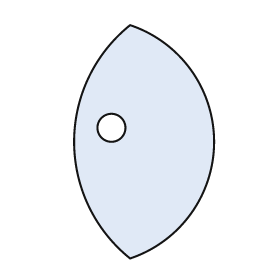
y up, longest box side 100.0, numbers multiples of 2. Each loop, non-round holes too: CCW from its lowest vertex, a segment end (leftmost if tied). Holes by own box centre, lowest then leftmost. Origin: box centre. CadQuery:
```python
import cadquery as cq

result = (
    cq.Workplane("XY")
    .moveTo(-6.0, -50.0)
    .threePointArc((30.0, 0.0), (-6.0, 50.0))
    .threePointArc((-30.0, 0.0), (-6.0, -50.0))
    .close()
    .moveTo(-14.0, 6.0)
    .circle(6.0)
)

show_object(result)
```